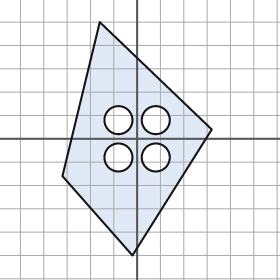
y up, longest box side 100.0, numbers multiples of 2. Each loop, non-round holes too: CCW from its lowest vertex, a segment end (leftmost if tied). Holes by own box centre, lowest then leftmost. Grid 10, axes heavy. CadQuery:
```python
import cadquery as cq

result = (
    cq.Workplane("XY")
    .moveTo(-2.0, -50.0)
    .lineTo(32.0, 4.0)
    .lineTo(-16.0, 50.0)
    .lineTo(-32.0, -16.0)
    .close()
    .moveTo(-8.0, -8.0)
    .circle(6.0)
    .moveTo(8.0, -8.0)
    .circle(6.0)
    .moveTo(-8.0, 8.0)
    .circle(6.0)
    .moveTo(8.0, 8.0)
    .circle(6.0)
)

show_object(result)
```